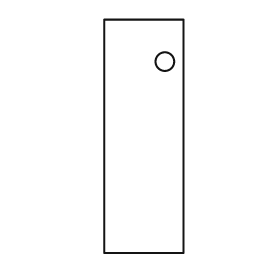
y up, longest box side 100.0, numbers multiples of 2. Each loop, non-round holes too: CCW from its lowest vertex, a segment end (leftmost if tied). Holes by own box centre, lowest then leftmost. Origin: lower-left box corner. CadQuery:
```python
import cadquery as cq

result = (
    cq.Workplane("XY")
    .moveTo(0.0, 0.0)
    .lineTo(34.0, 0.0)
    .lineTo(34.0, 100.0)
    .lineTo(0.0, 100.0)
    .close()
    .moveTo(26.0, 82.0)
    .circle(4.0)
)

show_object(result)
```